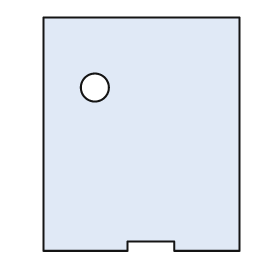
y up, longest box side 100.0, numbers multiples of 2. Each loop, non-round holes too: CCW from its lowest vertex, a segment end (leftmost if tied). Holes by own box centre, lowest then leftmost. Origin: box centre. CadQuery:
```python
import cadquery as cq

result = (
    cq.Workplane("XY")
    .moveTo(-42.0, -50.0)
    .lineTo(-6.0, -50.0)
    .lineTo(-6.0, -46.0)
    .lineTo(14.0, -46.0)
    .lineTo(14.0, -50.0)
    .lineTo(42.0, -50.0)
    .lineTo(42.0, 50.0)
    .lineTo(-42.0, 50.0)
    .close()
    .moveTo(-20.0, 20.0)
    .circle(6.0)
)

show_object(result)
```